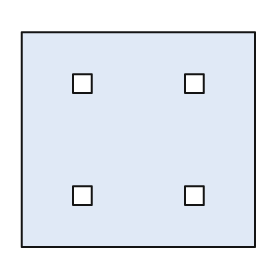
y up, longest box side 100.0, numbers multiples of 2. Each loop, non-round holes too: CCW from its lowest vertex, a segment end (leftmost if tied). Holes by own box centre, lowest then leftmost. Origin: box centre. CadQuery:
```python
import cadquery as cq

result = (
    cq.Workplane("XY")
    .moveTo(-50.0, -46.0)
    .lineTo(50.0, -46.0)
    .lineTo(50.0, 46.0)
    .lineTo(-50.0, 46.0)
    .close()
    .moveTo(-28.0, -28.0)
    .lineTo(-20.0, -28.0)
    .lineTo(-20.0, -20.0)
    .lineTo(-28.0, -20.0)
    .close()
    .moveTo(20.0, -28.0)
    .lineTo(28.0, -28.0)
    .lineTo(28.0, -20.0)
    .lineTo(20.0, -20.0)
    .close()
    .moveTo(-28.0, 20.0)
    .lineTo(-20.0, 20.0)
    .lineTo(-20.0, 28.0)
    .lineTo(-28.0, 28.0)
    .close()
    .moveTo(20.0, 20.0)
    .lineTo(28.0, 20.0)
    .lineTo(28.0, 28.0)
    .lineTo(20.0, 28.0)
    .close()
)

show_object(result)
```